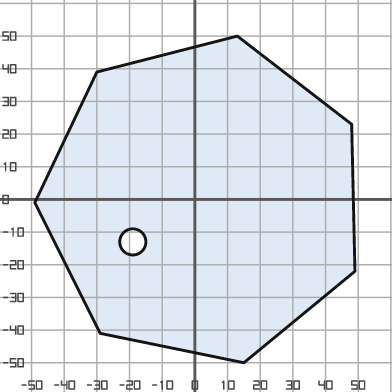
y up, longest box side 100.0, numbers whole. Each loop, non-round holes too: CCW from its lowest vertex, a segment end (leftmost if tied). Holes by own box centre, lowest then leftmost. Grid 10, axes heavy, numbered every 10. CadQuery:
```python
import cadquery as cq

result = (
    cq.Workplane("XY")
    .moveTo(15.0, -50.0)
    .lineTo(49.0, -22.0)
    .lineTo(48.0, 23.0)
    .lineTo(13.0, 50.0)
    .lineTo(-30.0, 39.0)
    .lineTo(-49.0, -1.0)
    .lineTo(-29.0, -41.0)
    .close()
    .moveTo(-19.0, -13.0)
    .circle(4.0)
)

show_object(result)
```